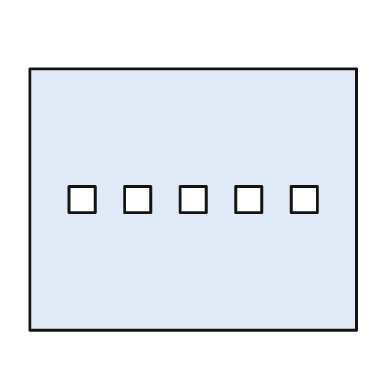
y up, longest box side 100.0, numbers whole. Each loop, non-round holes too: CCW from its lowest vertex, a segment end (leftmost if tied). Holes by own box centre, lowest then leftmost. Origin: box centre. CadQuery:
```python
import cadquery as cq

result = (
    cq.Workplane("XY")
    .moveTo(-50.0, -40.0)
    .lineTo(50.0, -40.0)
    .lineTo(50.0, 40.0)
    .lineTo(-50.0, 40.0)
    .close()
    .moveTo(-38.0, -4.0)
    .lineTo(-30.0, -4.0)
    .lineTo(-30.0, 4.0)
    .lineTo(-38.0, 4.0)
    .close()
    .moveTo(-21.0, -4.0)
    .lineTo(-13.0, -4.0)
    .lineTo(-13.0, 4.0)
    .lineTo(-21.0, 4.0)
    .close()
    .moveTo(-4.0, -4.0)
    .lineTo(4.0, -4.0)
    .lineTo(4.0, 4.0)
    .lineTo(-4.0, 4.0)
    .close()
    .moveTo(13.0, -4.0)
    .lineTo(21.0, -4.0)
    .lineTo(21.0, 4.0)
    .lineTo(13.0, 4.0)
    .close()
    .moveTo(30.0, -4.0)
    .lineTo(38.0, -4.0)
    .lineTo(38.0, 4.0)
    .lineTo(30.0, 4.0)
    .close()
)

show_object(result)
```